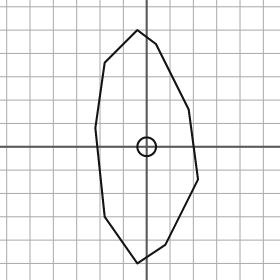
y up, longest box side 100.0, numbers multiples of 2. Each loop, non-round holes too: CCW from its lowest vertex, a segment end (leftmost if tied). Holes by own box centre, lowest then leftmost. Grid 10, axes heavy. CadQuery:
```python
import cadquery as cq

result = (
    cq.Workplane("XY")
    .moveTo(-4.0, -50.0)
    .lineTo(8.0, -42.0)
    .lineTo(22.0, -14.0)
    .lineTo(18.0, 16.0)
    .lineTo(4.0, 44.0)
    .lineTo(-4.0, 50.0)
    .lineTo(-18.0, 36.0)
    .lineTo(-22.0, 8.0)
    .lineTo(-18.0, -30.0)
    .close()
    .moveTo(0.0, 0.0)
    .circle(4.0)
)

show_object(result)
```